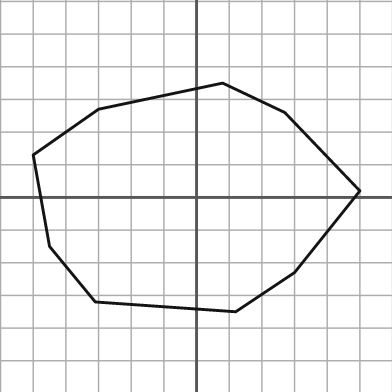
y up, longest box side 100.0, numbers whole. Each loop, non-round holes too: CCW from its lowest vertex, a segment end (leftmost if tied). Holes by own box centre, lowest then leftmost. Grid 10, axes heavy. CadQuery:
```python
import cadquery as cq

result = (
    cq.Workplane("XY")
    .moveTo(12.0, -35.0)
    .lineTo(30.0, -23.0)
    .lineTo(50.0, 2.0)
    .lineTo(27.0, 26.0)
    .lineTo(8.0, 35.0)
    .lineTo(-30.0, 27.0)
    .lineTo(-50.0, 13.0)
    .lineTo(-45.0, -15.0)
    .lineTo(-31.0, -32.0)
    .close()
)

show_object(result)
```